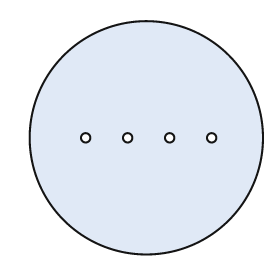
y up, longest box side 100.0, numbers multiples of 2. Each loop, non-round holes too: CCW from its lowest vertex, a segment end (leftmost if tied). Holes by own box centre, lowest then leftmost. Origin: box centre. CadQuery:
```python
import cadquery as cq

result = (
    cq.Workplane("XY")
    .moveTo(0.0, 0.0)
    .circle(50.0)
    .moveTo(-26.0, 0.0)
    .circle(2.0)
    .moveTo(-8.0, 0.0)
    .circle(2.0)
    .moveTo(10.0, 0.0)
    .circle(2.0)
    .moveTo(28.0, 0.0)
    .circle(2.0)
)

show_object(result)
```